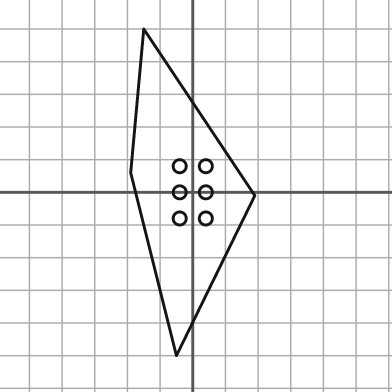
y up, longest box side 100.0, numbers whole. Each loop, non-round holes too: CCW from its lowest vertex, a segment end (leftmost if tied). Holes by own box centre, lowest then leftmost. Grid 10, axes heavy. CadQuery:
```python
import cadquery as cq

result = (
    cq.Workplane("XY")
    .moveTo(-5.0, -50.0)
    .lineTo(19.0, -1.0)
    .lineTo(-15.0, 50.0)
    .lineTo(-19.0, 6.0)
    .close()
    .moveTo(-4.0, -8.0)
    .circle(2.0)
    .moveTo(4.0, -8.0)
    .circle(2.0)
    .moveTo(-4.0, 0.0)
    .circle(2.0)
    .moveTo(4.0, 0.0)
    .circle(2.0)
    .moveTo(-4.0, 8.0)
    .circle(2.0)
    .moveTo(4.0, 8.0)
    .circle(2.0)
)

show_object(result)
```